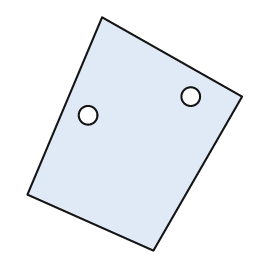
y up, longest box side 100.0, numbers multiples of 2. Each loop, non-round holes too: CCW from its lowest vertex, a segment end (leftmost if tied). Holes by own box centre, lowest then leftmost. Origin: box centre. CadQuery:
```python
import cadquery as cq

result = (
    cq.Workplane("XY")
    .moveTo(8.0, -50.0)
    .lineTo(46.0, 16.0)
    .lineTo(-14.0, 50.0)
    .lineTo(-46.0, -26.0)
    .close()
    .moveTo(-20.0, 8.0)
    .circle(4.0)
    .moveTo(24.0, 16.0)
    .circle(4.0)
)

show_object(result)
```